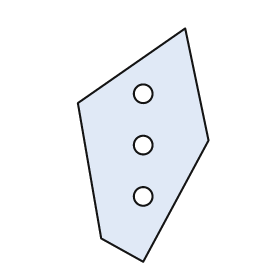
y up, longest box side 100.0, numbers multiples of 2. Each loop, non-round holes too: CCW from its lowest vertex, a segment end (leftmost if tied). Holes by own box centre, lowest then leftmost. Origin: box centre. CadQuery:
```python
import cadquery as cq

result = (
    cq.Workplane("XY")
    .moveTo(0.0, -50.0)
    .lineTo(28.0, 2.0)
    .lineTo(18.0, 50.0)
    .lineTo(-28.0, 18.0)
    .lineTo(-18.0, -40.0)
    .close()
    .moveTo(0.0, -22.0)
    .circle(4.0)
    .moveTo(0.0, 0.0)
    .circle(4.0)
    .moveTo(0.0, 22.0)
    .circle(4.0)
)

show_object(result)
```